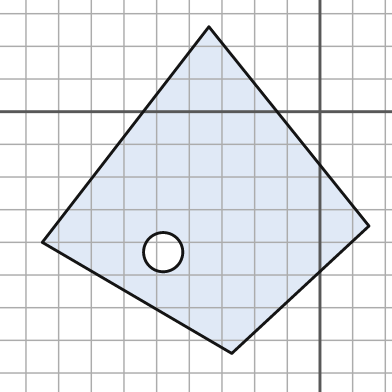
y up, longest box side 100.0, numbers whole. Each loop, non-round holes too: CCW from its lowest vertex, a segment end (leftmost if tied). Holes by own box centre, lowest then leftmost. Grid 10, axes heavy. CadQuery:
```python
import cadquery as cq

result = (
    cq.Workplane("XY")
    .moveTo(-27.0, -74.0)
    .lineTo(15.0, -35.0)
    .lineTo(-34.0, 26.0)
    .lineTo(-85.0, -40.0)
    .close()
    .moveTo(-48.0, -43.0)
    .circle(6.0)
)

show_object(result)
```